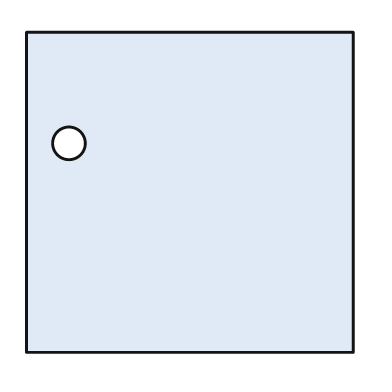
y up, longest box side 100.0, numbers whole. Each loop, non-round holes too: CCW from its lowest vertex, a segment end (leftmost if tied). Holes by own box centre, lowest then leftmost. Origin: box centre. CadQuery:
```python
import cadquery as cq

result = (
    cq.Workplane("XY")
    .moveTo(-50.0, -49.0)
    .lineTo(50.0, -49.0)
    .lineTo(50.0, 49.0)
    .lineTo(-50.0, 49.0)
    .close()
    .moveTo(-37.0, 15.0)
    .circle(5.0)
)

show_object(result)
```